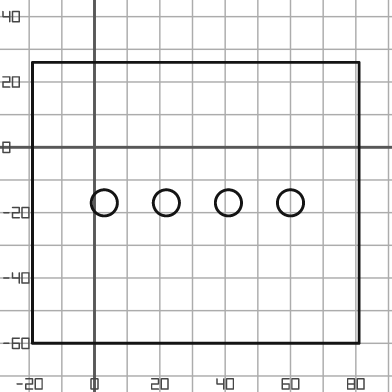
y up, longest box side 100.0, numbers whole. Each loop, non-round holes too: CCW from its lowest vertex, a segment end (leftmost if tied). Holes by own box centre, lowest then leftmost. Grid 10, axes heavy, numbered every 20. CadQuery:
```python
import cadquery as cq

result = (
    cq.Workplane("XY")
    .moveTo(-19.0, -60.0)
    .lineTo(81.0, -60.0)
    .lineTo(81.0, 26.0)
    .lineTo(-19.0, 26.0)
    .close()
    .moveTo(3.0, -17.0)
    .circle(4.0)
    .moveTo(22.0, -17.0)
    .circle(4.0)
    .moveTo(41.0, -17.0)
    .circle(4.0)
    .moveTo(60.0, -17.0)
    .circle(4.0)
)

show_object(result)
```